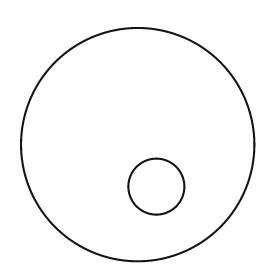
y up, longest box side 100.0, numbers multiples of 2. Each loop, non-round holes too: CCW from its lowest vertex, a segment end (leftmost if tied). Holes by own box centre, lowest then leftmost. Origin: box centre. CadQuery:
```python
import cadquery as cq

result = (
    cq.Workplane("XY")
    .moveTo(0.0, 0.0)
    .circle(50.0)
    .moveTo(8.0, -18.0)
    .circle(12.0)
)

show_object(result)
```